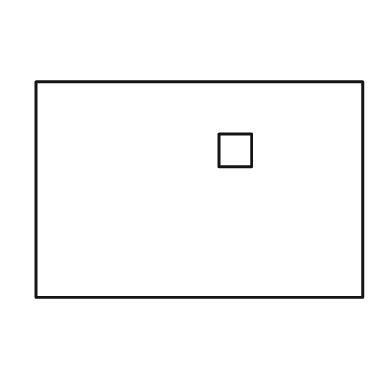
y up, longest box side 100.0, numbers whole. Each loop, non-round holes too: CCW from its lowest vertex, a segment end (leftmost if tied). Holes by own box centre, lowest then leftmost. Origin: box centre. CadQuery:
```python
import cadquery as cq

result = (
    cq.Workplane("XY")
    .moveTo(-50.0, -33.0)
    .lineTo(50.0, -33.0)
    .lineTo(50.0, 33.0)
    .lineTo(-50.0, 33.0)
    .close()
    .moveTo(6.0, 7.0)
    .lineTo(16.0, 7.0)
    .lineTo(16.0, 17.0)
    .lineTo(6.0, 17.0)
    .close()
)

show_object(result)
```